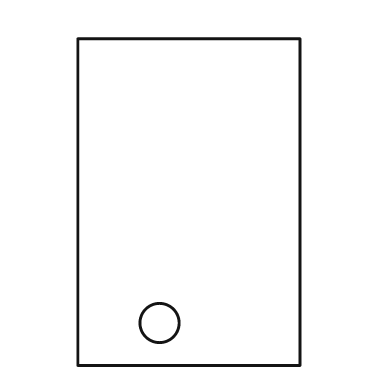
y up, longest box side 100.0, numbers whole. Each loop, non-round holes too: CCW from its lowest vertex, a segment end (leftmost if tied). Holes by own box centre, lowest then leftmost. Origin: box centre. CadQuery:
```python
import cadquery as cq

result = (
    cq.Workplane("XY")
    .moveTo(-34.0, -50.0)
    .lineTo(34.0, -50.0)
    .lineTo(34.0, 50.0)
    .lineTo(-34.0, 50.0)
    .close()
    .moveTo(-9.0, -37.0)
    .circle(6.0)
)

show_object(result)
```